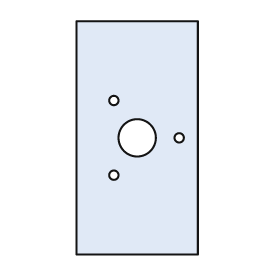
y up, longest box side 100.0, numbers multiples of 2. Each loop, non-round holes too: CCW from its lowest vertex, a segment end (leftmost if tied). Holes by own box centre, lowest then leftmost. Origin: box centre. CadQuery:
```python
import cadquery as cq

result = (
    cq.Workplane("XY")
    .moveTo(-26.0, -50.0)
    .lineTo(26.0, -50.0)
    .lineTo(26.0, 50.0)
    .lineTo(-26.0, 50.0)
    .close()
    .moveTo(-10.0, -16.0)
    .circle(2.0)
    .moveTo(0.0, 0.0)
    .circle(8.0)
    .moveTo(18.0, 0.0)
    .circle(2.0)
    .moveTo(-10.0, 16.0)
    .circle(2.0)
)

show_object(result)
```